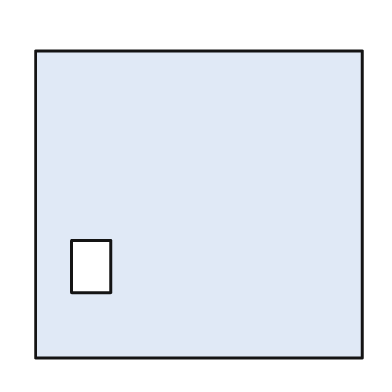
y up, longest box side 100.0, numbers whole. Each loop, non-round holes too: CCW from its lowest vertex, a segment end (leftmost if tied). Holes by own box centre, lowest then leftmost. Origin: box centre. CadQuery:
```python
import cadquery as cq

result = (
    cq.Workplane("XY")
    .moveTo(-50.0, -47.0)
    .lineTo(50.0, -47.0)
    .lineTo(50.0, 47.0)
    .lineTo(-50.0, 47.0)
    .close()
    .moveTo(-39.0, -27.0)
    .lineTo(-27.0, -27.0)
    .lineTo(-27.0, -11.0)
    .lineTo(-39.0, -11.0)
    .close()
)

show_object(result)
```